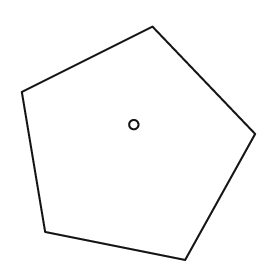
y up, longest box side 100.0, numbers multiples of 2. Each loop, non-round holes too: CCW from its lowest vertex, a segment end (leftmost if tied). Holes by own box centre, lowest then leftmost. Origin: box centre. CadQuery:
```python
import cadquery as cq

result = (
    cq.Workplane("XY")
    .moveTo(20.0, -50.0)
    .lineTo(50.0, 4.0)
    .lineTo(6.0, 50.0)
    .lineTo(-50.0, 22.0)
    .lineTo(-40.0, -38.0)
    .close()
    .moveTo(-2.0, 8.0)
    .circle(2.0)
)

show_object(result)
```